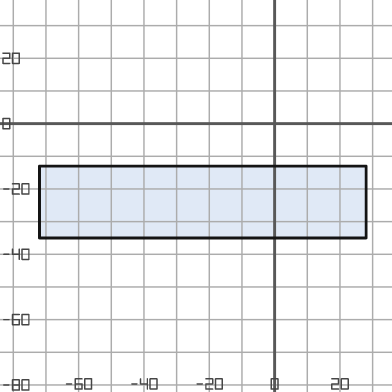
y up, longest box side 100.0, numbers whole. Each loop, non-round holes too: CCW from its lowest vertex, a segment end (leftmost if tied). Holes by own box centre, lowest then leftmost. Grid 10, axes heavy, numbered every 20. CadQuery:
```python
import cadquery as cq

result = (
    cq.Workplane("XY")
    .moveTo(-72.0, -35.0)
    .lineTo(28.0, -35.0)
    .lineTo(28.0, -13.0)
    .lineTo(-72.0, -13.0)
    .close()
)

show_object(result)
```